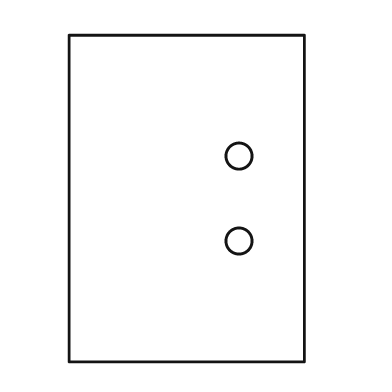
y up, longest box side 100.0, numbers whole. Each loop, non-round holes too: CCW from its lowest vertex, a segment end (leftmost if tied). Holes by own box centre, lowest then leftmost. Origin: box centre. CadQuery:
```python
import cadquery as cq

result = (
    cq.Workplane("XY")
    .moveTo(-36.0, -50.0)
    .lineTo(36.0, -50.0)
    .lineTo(36.0, 50.0)
    .lineTo(-36.0, 50.0)
    .close()
    .moveTo(16.0, -13.0)
    .circle(4.0)
    .moveTo(16.0, 13.0)
    .circle(4.0)
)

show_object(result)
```